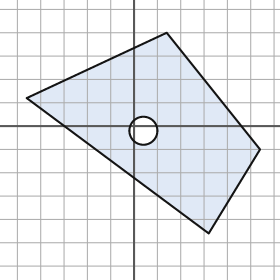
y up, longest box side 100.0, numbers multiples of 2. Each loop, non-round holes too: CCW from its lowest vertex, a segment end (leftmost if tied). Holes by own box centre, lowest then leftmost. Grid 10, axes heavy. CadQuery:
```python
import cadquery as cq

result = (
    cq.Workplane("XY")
    .moveTo(32.0, -46.0)
    .lineTo(54.0, -10.0)
    .lineTo(14.0, 40.0)
    .lineTo(-46.0, 12.0)
    .close()
    .moveTo(4.0, -2.0)
    .circle(6.0)
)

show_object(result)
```